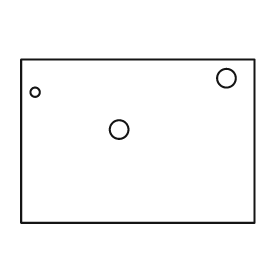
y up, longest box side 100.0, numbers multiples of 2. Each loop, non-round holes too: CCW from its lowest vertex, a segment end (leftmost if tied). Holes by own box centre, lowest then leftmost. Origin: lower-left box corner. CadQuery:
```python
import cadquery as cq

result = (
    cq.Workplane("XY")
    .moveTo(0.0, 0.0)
    .lineTo(100.0, 0.0)
    .lineTo(100.0, 70.0)
    .lineTo(0.0, 70.0)
    .close()
    .moveTo(42.0, 40.0)
    .circle(4.0)
    .moveTo(6.0, 56.0)
    .circle(2.0)
    .moveTo(88.0, 62.0)
    .circle(4.0)
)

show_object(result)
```